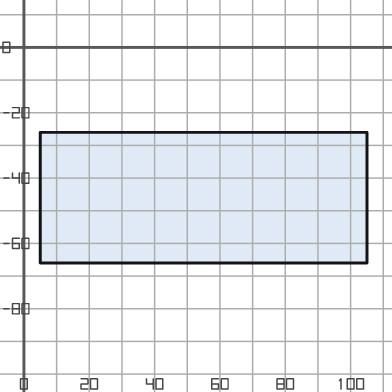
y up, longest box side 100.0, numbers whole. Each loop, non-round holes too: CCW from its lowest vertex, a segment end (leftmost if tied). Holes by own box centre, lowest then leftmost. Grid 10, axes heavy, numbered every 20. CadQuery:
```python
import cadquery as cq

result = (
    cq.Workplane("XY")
    .moveTo(5.0, -66.0)
    .lineTo(105.0, -66.0)
    .lineTo(105.0, -26.0)
    .lineTo(5.0, -26.0)
    .close()
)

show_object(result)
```